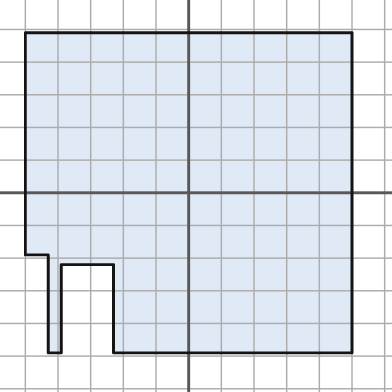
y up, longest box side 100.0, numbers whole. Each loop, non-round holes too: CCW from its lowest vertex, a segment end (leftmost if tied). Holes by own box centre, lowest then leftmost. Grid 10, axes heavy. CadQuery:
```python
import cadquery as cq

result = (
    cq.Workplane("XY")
    .moveTo(-43.0, -49.0)
    .lineTo(-39.0, -49.0)
    .lineTo(-39.0, -22.0)
    .lineTo(-23.0, -22.0)
    .lineTo(-23.0, -49.0)
    .lineTo(50.0, -49.0)
    .lineTo(50.0, 49.0)
    .lineTo(-50.0, 49.0)
    .lineTo(-50.0, -19.0)
    .lineTo(-43.0, -19.0)
    .close()
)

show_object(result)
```